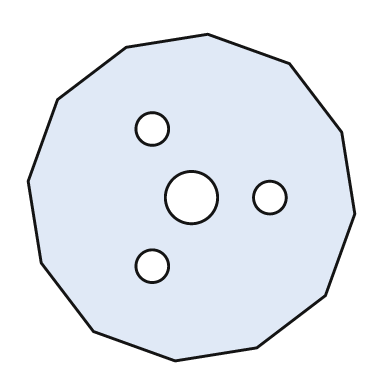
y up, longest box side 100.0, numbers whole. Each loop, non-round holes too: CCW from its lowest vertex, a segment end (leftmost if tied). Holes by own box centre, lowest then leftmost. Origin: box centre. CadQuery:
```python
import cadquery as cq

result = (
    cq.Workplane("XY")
    .moveTo(-5.0, -50.0)
    .lineTo(20.0, -46.0)
    .lineTo(41.0, -30.0)
    .lineTo(50.0, -5.0)
    .lineTo(46.0, 20.0)
    .lineTo(30.0, 41.0)
    .lineTo(5.0, 50.0)
    .lineTo(-20.0, 46.0)
    .lineTo(-41.0, 30.0)
    .lineTo(-50.0, 5.0)
    .lineTo(-46.0, -20.0)
    .lineTo(-30.0, -41.0)
    .close()
    .moveTo(-12.0, -21.0)
    .circle(5.0)
    .moveTo(0.0, 0.0)
    .circle(8.0)
    .moveTo(24.0, 0.0)
    .circle(5.0)
    .moveTo(-12.0, 21.0)
    .circle(5.0)
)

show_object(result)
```